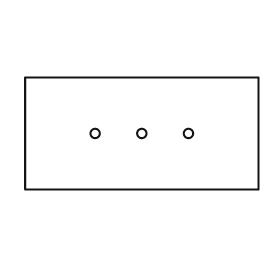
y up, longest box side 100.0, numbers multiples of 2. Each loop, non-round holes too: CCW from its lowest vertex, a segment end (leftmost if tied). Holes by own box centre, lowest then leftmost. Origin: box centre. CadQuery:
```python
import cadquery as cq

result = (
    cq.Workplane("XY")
    .moveTo(-50.0, -24.0)
    .lineTo(50.0, -24.0)
    .lineTo(50.0, 24.0)
    .lineTo(-50.0, 24.0)
    .close()
    .moveTo(-20.0, 0.0)
    .circle(2.0)
    .moveTo(0.0, 0.0)
    .circle(2.0)
    .moveTo(20.0, 0.0)
    .circle(2.0)
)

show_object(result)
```